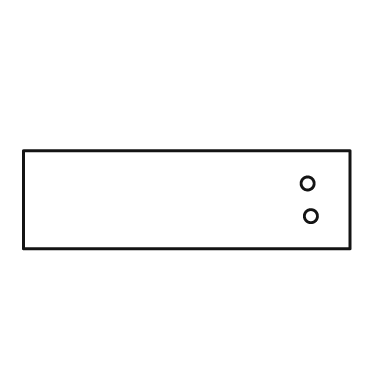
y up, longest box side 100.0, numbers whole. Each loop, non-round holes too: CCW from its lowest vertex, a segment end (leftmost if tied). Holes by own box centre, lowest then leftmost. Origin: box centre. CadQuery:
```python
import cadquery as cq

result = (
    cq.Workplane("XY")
    .moveTo(-50.0, -15.0)
    .lineTo(50.0, -15.0)
    .lineTo(50.0, 15.0)
    .lineTo(-50.0, 15.0)
    .close()
    .moveTo(38.0, -5.0)
    .circle(2.0)
    .moveTo(37.0, 5.0)
    .circle(2.0)
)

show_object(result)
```